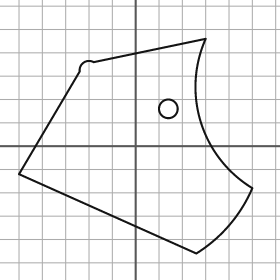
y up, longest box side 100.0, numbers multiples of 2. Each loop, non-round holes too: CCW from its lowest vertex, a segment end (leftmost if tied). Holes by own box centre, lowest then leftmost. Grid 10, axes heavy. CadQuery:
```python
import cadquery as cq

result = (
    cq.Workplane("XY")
    .moveTo(26.0, -46.0)
    .threePointArc((40.0, -34.0), (50.0, -18.0))
    .threePointArc((28.0, 10.0), (30.0, 46.0))
    .lineTo(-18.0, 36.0)
    .threePointArc((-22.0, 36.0), (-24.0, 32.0))
    .lineTo(-50.0, -12.0)
    .close()
    .moveTo(14.0, 16.0)
    .circle(4.0)
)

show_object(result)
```